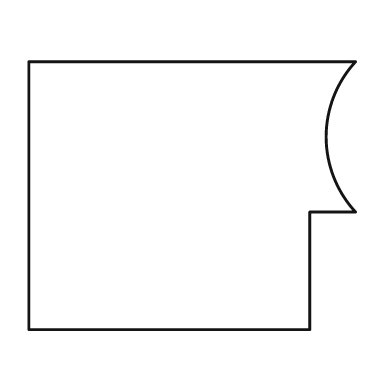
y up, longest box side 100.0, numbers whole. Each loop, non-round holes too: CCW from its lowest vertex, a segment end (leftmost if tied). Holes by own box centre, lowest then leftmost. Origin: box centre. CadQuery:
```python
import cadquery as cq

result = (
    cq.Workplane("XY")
    .moveTo(-50.0, -41.0)
    .lineTo(36.0, -41.0)
    .lineTo(36.0, -5.0)
    .lineTo(50.0, -5.0)
    .threePointArc((41.0, 18.0), (50.0, 41.0))
    .lineTo(-50.0, 41.0)
    .close()
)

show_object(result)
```